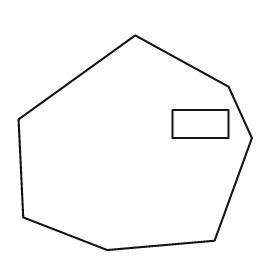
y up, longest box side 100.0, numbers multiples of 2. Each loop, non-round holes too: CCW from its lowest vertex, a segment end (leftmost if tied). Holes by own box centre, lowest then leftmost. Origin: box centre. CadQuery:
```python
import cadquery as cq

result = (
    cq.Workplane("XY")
    .moveTo(-12.0, -46.0)
    .lineTo(34.0, -42.0)
    .lineTo(50.0, 2.0)
    .lineTo(40.0, 24.0)
    .lineTo(0.0, 46.0)
    .lineTo(-50.0, 10.0)
    .lineTo(-48.0, -32.0)
    .close()
    .moveTo(16.0, 2.0)
    .lineTo(40.0, 2.0)
    .lineTo(40.0, 14.0)
    .lineTo(16.0, 14.0)
    .close()
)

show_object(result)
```